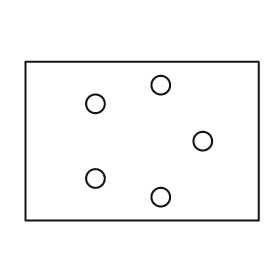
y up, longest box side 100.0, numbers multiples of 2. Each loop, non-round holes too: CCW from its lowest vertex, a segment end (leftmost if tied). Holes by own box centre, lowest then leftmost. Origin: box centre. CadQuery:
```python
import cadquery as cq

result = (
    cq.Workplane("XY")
    .moveTo(-50.0, -34.0)
    .lineTo(50.0, -34.0)
    .lineTo(50.0, 34.0)
    .lineTo(-50.0, 34.0)
    .close()
    .moveTo(8.0, -24.0)
    .circle(4.0)
    .moveTo(-20.0, -16.0)
    .circle(4.0)
    .moveTo(26.0, 0.0)
    .circle(4.0)
    .moveTo(-20.0, 16.0)
    .circle(4.0)
    .moveTo(8.0, 24.0)
    .circle(4.0)
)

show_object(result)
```